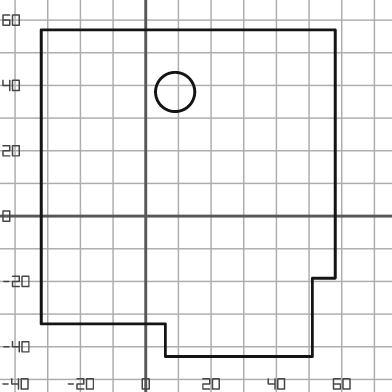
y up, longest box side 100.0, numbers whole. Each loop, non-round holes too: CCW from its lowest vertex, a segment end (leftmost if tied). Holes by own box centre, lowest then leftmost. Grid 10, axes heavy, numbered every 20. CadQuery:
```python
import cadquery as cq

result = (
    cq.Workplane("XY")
    .moveTo(6.0, -43.0)
    .lineTo(51.0, -43.0)
    .lineTo(51.0, -19.0)
    .lineTo(58.0, -19.0)
    .lineTo(58.0, 57.0)
    .lineTo(-32.0, 57.0)
    .lineTo(-32.0, -33.0)
    .lineTo(6.0, -33.0)
    .close()
    .moveTo(9.0, 38.0)
    .circle(6.0)
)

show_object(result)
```